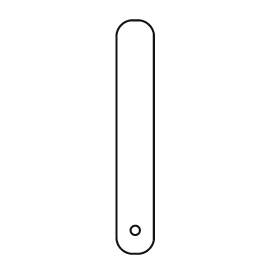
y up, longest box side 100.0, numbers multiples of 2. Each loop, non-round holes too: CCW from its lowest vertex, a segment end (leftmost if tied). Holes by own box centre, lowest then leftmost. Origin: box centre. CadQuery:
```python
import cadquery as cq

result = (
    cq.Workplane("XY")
    .moveTo(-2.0, -50.0)
    .lineTo(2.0, -50.0)
    .threePointArc((6.0, -48.0), (8.0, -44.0))
    .lineTo(8.0, 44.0)
    .threePointArc((6.0, 48.0), (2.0, 50.0))
    .lineTo(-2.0, 50.0)
    .threePointArc((-6.0, 48.0), (-8.0, 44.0))
    .lineTo(-8.0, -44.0)
    .threePointArc((-6.0, -48.0), (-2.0, -50.0))
    .close()
    .moveTo(0.0, -40.0)
    .circle(2.0)
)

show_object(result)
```